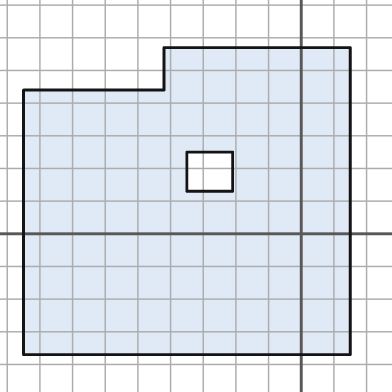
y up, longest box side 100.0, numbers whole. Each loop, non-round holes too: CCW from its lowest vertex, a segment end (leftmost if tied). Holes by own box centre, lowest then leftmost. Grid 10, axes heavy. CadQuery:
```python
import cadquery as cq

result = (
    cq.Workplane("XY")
    .moveTo(-85.0, -37.0)
    .lineTo(15.0, -37.0)
    .lineTo(15.0, 57.0)
    .lineTo(-42.0, 57.0)
    .lineTo(-42.0, 44.0)
    .lineTo(-85.0, 44.0)
    .close()
    .moveTo(-35.0, 13.0)
    .lineTo(-21.0, 13.0)
    .lineTo(-21.0, 25.0)
    .lineTo(-35.0, 25.0)
    .close()
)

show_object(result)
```